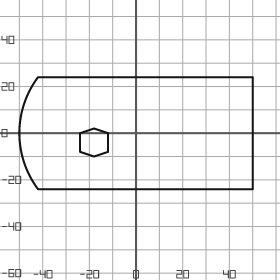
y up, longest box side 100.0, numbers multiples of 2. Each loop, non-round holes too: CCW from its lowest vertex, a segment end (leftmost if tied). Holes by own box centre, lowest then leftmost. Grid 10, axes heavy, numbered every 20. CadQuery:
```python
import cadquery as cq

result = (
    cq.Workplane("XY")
    .moveTo(-42.0, -24.0)
    .lineTo(50.0, -24.0)
    .lineTo(50.0, 24.0)
    .lineTo(-42.0, 24.0)
    .threePointArc((-50.0, 0.0), (-42.0, -24.0))
    .close()
    .moveTo(-18.0, -10.0)
    .lineTo(-12.0, -8.0)
    .lineTo(-12.0, 0.0)
    .lineTo(-18.0, 2.0)
    .lineTo(-24.0, 0.0)
    .lineTo(-24.0, -8.0)
    .close()
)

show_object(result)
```